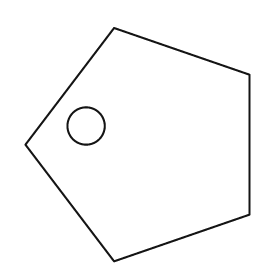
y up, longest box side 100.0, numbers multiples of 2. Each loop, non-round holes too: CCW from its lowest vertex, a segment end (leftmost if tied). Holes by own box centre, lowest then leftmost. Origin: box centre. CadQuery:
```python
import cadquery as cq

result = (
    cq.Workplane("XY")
    .moveTo(-10.0, -50.0)
    .lineTo(48.0, -30.0)
    .lineTo(48.0, 30.0)
    .lineTo(-10.0, 50.0)
    .lineTo(-48.0, 0.0)
    .close()
    .moveTo(-22.0, 8.0)
    .circle(8.0)
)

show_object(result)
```